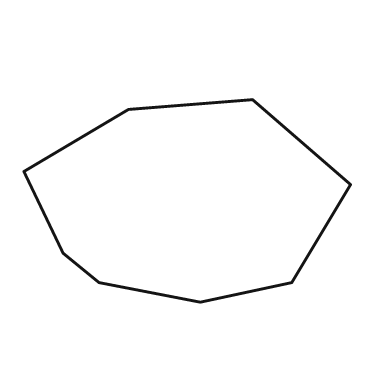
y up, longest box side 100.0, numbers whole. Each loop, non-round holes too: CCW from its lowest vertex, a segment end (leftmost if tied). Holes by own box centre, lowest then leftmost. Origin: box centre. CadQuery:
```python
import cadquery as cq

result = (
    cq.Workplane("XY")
    .moveTo(4.0, -31.0)
    .lineTo(32.0, -25.0)
    .lineTo(50.0, 5.0)
    .lineTo(20.0, 31.0)
    .lineTo(-18.0, 28.0)
    .lineTo(-50.0, 9.0)
    .lineTo(-38.0, -16.0)
    .lineTo(-27.0, -25.0)
    .close()
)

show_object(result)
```